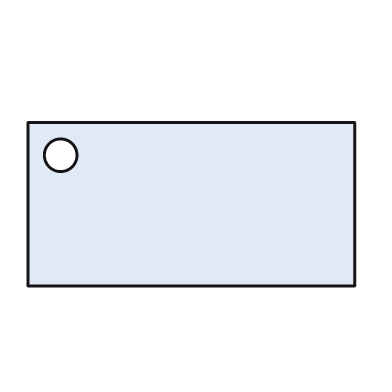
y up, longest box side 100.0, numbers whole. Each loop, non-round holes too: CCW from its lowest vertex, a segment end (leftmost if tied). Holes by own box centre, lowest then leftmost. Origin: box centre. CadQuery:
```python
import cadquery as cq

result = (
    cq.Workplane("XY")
    .moveTo(-50.0, -25.0)
    .lineTo(50.0, -25.0)
    .lineTo(50.0, 25.0)
    .lineTo(-50.0, 25.0)
    .close()
    .moveTo(-40.0, 15.0)
    .circle(5.0)
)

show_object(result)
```